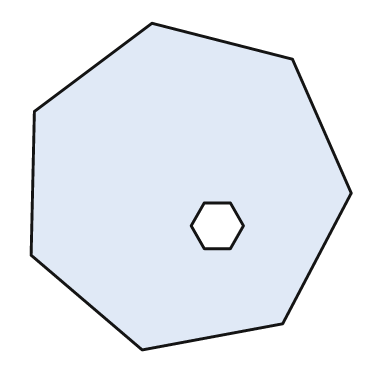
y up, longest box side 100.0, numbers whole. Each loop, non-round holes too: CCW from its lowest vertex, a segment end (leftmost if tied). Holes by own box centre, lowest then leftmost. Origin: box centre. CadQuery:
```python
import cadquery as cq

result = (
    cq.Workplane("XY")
    .moveTo(-15.0, -50.0)
    .lineTo(28.0, -42.0)
    .lineTo(49.0, -2.0)
    .lineTo(31.0, 39.0)
    .lineTo(-12.0, 50.0)
    .lineTo(-48.0, 23.0)
    .lineTo(-49.0, -21.0)
    .close()
    .moveTo(4.0, -19.0)
    .lineTo(12.0, -19.0)
    .lineTo(16.0, -12.0)
    .lineTo(12.0, -5.0)
    .lineTo(4.0, -5.0)
    .lineTo(0.0, -12.0)
    .close()
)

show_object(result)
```